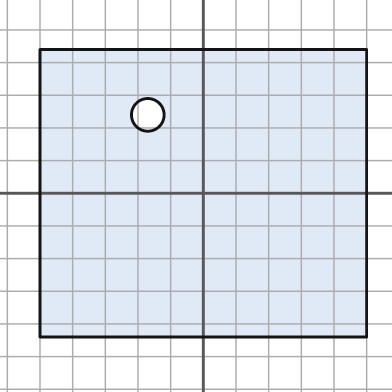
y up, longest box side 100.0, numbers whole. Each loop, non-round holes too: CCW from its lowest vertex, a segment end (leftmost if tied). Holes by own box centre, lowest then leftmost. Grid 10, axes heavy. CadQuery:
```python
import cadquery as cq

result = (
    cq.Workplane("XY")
    .moveTo(-50.0, -44.0)
    .lineTo(50.0, -44.0)
    .lineTo(50.0, 44.0)
    .lineTo(-50.0, 44.0)
    .close()
    .moveTo(-17.0, 24.0)
    .circle(5.0)
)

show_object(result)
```